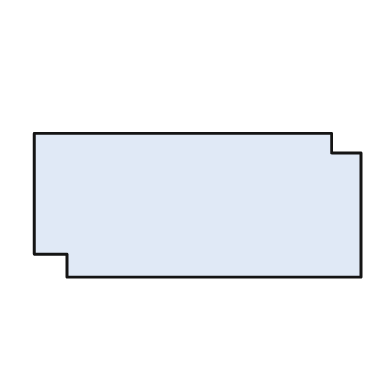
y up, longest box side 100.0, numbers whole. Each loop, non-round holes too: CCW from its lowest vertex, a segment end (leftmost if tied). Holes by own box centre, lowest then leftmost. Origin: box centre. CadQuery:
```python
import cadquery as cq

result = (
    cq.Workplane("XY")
    .moveTo(-40.0, -22.0)
    .lineTo(50.0, -22.0)
    .lineTo(50.0, 16.0)
    .lineTo(41.0, 16.0)
    .lineTo(41.0, 22.0)
    .lineTo(-50.0, 22.0)
    .lineTo(-50.0, -15.0)
    .lineTo(-40.0, -15.0)
    .close()
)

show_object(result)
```